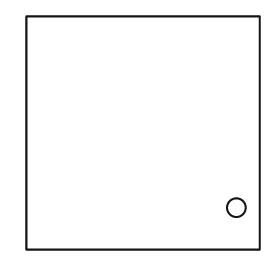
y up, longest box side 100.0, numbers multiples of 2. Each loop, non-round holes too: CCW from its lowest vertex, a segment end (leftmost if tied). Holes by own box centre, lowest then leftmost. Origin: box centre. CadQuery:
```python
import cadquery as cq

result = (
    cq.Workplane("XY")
    .moveTo(-50.0, -50.0)
    .lineTo(50.0, -50.0)
    .lineTo(50.0, 50.0)
    .lineTo(-50.0, 50.0)
    .close()
    .moveTo(40.0, -32.0)
    .circle(4.0)
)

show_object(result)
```